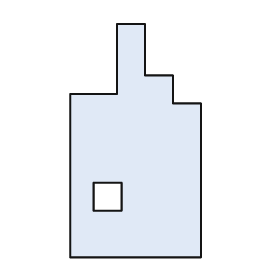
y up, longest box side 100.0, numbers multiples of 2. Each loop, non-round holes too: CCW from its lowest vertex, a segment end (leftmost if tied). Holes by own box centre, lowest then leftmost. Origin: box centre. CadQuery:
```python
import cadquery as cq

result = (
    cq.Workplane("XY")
    .moveTo(-28.0, -50.0)
    .lineTo(28.0, -50.0)
    .lineTo(28.0, 16.0)
    .lineTo(16.0, 16.0)
    .lineTo(16.0, 28.0)
    .lineTo(4.0, 28.0)
    .lineTo(4.0, 50.0)
    .lineTo(-8.0, 50.0)
    .lineTo(-8.0, 20.0)
    .lineTo(-28.0, 20.0)
    .close()
    .moveTo(-18.0, -30.0)
    .lineTo(-6.0, -30.0)
    .lineTo(-6.0, -18.0)
    .lineTo(-18.0, -18.0)
    .close()
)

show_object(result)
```